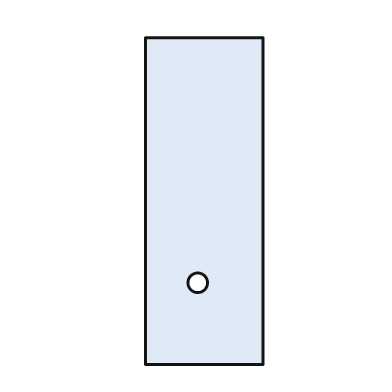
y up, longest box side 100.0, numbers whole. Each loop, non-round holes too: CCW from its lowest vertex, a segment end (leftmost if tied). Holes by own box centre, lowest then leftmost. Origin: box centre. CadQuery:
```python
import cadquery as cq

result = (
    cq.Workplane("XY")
    .moveTo(-18.0, -50.0)
    .lineTo(18.0, -50.0)
    .lineTo(18.0, 50.0)
    .lineTo(-18.0, 50.0)
    .close()
    .moveTo(-2.0, -25.0)
    .circle(3.0)
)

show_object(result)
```